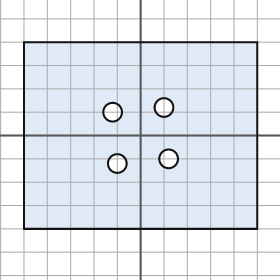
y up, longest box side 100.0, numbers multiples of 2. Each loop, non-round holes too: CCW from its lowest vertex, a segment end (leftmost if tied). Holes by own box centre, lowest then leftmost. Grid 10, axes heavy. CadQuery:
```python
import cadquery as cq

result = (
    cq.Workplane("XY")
    .moveTo(-50.0, -40.0)
    .lineTo(50.0, -40.0)
    .lineTo(50.0, 40.0)
    .lineTo(-50.0, 40.0)
    .close()
    .moveTo(-10.0, -12.0)
    .circle(4.0)
    .moveTo(12.0, -10.0)
    .circle(4.0)
    .moveTo(-12.0, 10.0)
    .circle(4.0)
    .moveTo(10.0, 12.0)
    .circle(4.0)
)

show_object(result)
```